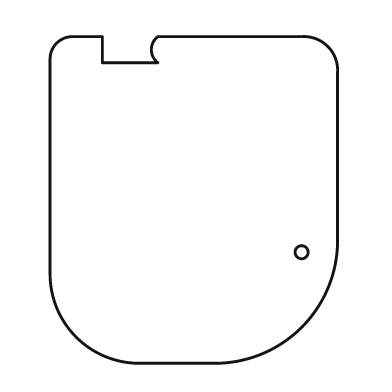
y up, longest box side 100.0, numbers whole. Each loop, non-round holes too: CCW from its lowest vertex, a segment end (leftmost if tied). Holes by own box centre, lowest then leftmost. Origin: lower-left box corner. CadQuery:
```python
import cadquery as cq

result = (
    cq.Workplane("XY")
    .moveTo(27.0, 0.0)
    .lineTo(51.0, 0.0)
    .threePointArc((77.0, 11.0), (88.0, 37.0))
    .lineTo(88.0, 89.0)
    .threePointArc((85.0, 97.0), (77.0, 100.0))
    .lineTo(33.0, 100.0)
    .threePointArc((31.0, 96.0), (33.0, 92.0))
    .lineTo(16.0, 92.0)
    .lineTo(16.0, 100.0)
    .lineTo(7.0, 100.0)
    .threePointArc((2.0, 98.0), (0.0, 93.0))
    .lineTo(0.0, 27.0)
    .threePointArc((8.0, 8.0), (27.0, 0.0))
    .close()
    .moveTo(77.0, 34.0)
    .circle(2.0)
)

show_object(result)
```